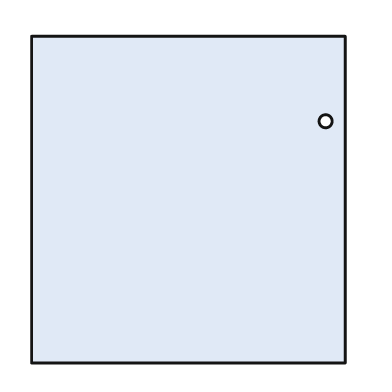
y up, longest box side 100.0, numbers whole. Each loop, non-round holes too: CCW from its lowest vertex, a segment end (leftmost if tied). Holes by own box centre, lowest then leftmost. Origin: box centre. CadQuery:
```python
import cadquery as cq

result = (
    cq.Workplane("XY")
    .moveTo(-48.0, -50.0)
    .lineTo(48.0, -50.0)
    .lineTo(48.0, 50.0)
    .lineTo(-48.0, 50.0)
    .close()
    .moveTo(42.0, 24.0)
    .circle(2.0)
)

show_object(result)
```